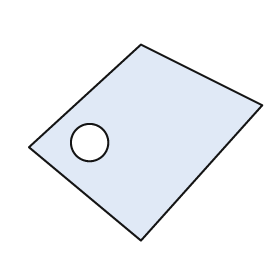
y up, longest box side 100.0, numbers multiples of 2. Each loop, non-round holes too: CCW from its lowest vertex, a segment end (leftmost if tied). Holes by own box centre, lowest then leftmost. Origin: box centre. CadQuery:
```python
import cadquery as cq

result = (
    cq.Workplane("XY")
    .moveTo(-2.0, -42.0)
    .lineTo(50.0, 16.0)
    .lineTo(-2.0, 42.0)
    .lineTo(-50.0, -2.0)
    .close()
    .moveTo(-24.0, 0.0)
    .circle(8.0)
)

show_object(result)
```